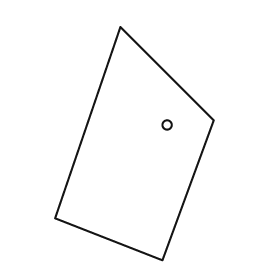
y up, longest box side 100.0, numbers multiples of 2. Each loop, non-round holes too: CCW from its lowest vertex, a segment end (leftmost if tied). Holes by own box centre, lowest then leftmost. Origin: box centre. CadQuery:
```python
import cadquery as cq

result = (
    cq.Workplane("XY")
    .moveTo(12.0, -50.0)
    .lineTo(34.0, 10.0)
    .lineTo(-6.0, 50.0)
    .lineTo(-34.0, -32.0)
    .close()
    .moveTo(14.0, 8.0)
    .circle(2.0)
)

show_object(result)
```